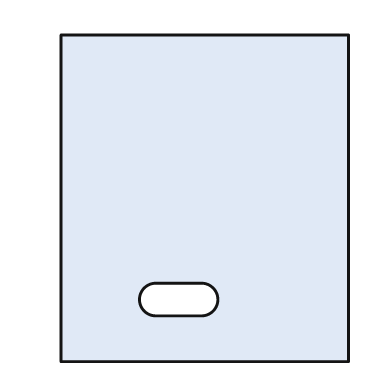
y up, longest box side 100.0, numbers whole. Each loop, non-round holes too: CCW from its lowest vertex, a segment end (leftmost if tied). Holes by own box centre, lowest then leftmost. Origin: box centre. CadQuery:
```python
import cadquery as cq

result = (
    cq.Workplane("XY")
    .moveTo(-44.0, -50.0)
    .lineTo(44.0, -50.0)
    .lineTo(44.0, 50.0)
    .lineTo(-44.0, 50.0)
    .close()
    .moveTo(-15.0, -36.0)
    .lineTo(-1.0, -36.0)
    .threePointArc((4.0, -31.0), (-1.0, -26.0))
    .lineTo(-15.0, -26.0)
    .threePointArc((-20.0, -31.0), (-15.0, -36.0))
    .close()
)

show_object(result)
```